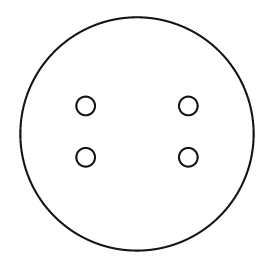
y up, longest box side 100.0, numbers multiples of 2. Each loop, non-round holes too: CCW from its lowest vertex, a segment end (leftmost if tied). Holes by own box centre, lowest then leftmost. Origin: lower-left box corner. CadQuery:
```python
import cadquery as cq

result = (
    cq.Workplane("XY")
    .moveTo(50.0, 50.0)
    .circle(50.0)
    .moveTo(28.0, 40.0)
    .circle(4.0)
    .moveTo(72.0, 40.0)
    .circle(4.0)
    .moveTo(28.0, 62.0)
    .circle(4.0)
    .moveTo(72.0, 62.0)
    .circle(4.0)
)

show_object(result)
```